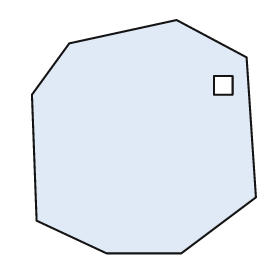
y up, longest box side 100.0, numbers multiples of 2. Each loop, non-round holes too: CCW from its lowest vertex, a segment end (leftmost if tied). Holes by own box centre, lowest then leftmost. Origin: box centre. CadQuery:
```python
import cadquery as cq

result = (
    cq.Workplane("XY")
    .moveTo(-16.0, -50.0)
    .lineTo(16.0, -50.0)
    .lineTo(48.0, -26.0)
    .lineTo(44.0, 34.0)
    .lineTo(14.0, 50.0)
    .lineTo(-32.0, 40.0)
    .lineTo(-48.0, 18.0)
    .lineTo(-46.0, -36.0)
    .close()
    .moveTo(30.0, 18.0)
    .lineTo(38.0, 18.0)
    .lineTo(38.0, 26.0)
    .lineTo(30.0, 26.0)
    .close()
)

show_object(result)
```